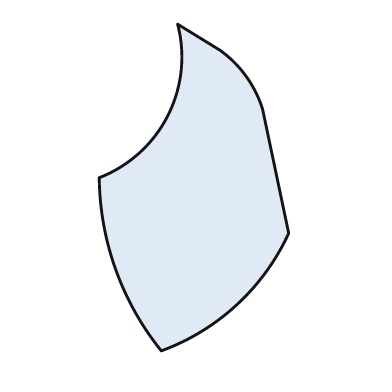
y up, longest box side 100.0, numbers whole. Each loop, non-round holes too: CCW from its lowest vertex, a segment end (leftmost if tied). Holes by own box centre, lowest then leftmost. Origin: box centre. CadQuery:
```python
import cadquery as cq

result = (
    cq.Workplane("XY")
    .moveTo(-10.0, -50.0)
    .threePointArc((13.0, -36.0), (29.0, -14.0))
    .lineTo(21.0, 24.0)
    .threePointArc((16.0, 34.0), (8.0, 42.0))
    .lineTo(-5.0, 50.0)
    .threePointArc((-8.0, 22.0), (-29.0, 3.0))
    .threePointArc((-24.0, -25.0), (-10.0, -50.0))
    .close()
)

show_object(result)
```